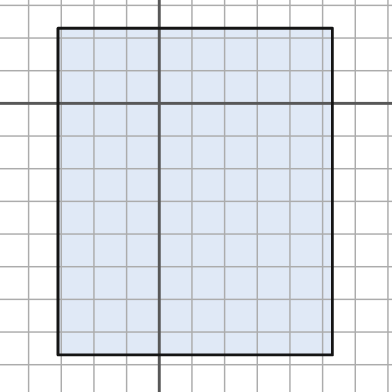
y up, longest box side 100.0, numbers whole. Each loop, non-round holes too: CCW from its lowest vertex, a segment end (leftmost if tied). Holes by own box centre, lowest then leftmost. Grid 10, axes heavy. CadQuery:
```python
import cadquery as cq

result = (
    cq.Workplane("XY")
    .moveTo(-31.0, -77.0)
    .lineTo(53.0, -77.0)
    .lineTo(53.0, 23.0)
    .lineTo(-31.0, 23.0)
    .close()
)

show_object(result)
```